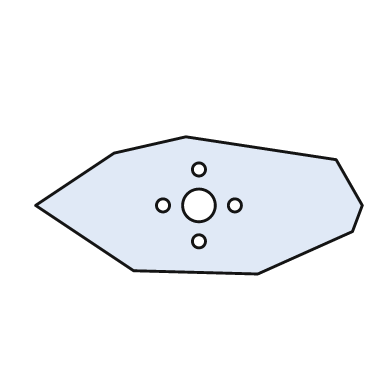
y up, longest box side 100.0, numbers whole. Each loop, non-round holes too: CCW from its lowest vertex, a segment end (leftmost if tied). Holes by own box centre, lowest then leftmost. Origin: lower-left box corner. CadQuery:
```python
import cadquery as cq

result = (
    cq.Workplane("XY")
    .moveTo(68.0, 0.0)
    .lineTo(97.0, 13.0)
    .lineTo(100.0, 21.0)
    .lineTo(92.0, 35.0)
    .lineTo(46.0, 42.0)
    .lineTo(24.0, 37.0)
    .lineTo(0.0, 21.0)
    .lineTo(30.0, 1.0)
    .close()
    .moveTo(50.0, 10.0)
    .circle(2.0)
    .moveTo(39.0, 21.0)
    .circle(2.0)
    .moveTo(50.0, 21.0)
    .circle(5.0)
    .moveTo(61.0, 21.0)
    .circle(2.0)
    .moveTo(50.0, 32.0)
    .circle(2.0)
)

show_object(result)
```